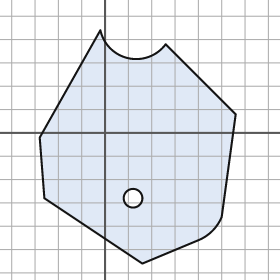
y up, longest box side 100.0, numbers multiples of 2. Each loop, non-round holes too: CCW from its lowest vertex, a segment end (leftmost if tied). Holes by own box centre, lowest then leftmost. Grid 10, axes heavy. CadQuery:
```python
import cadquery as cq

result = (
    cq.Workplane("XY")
    .moveTo(16.0, -56.0)
    .lineTo(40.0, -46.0)
    .threePointArc((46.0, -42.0), (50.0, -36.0))
    .lineTo(56.0, 8.0)
    .lineTo(26.0, 38.0)
    .threePointArc((10.0, 32.0), (-2.0, 44.0))
    .lineTo(-28.0, -2.0)
    .lineTo(-26.0, -28.0)
    .close()
    .moveTo(12.0, -28.0)
    .circle(4.0)
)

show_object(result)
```